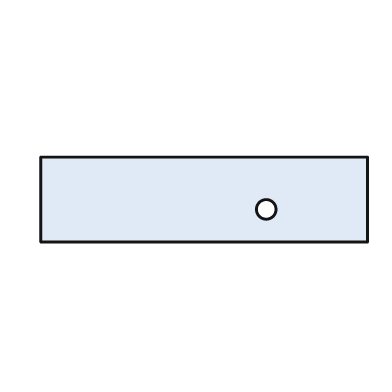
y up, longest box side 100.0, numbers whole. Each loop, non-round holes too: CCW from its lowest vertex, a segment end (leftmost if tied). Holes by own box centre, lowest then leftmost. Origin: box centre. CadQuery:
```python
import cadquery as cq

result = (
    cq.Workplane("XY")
    .moveTo(-50.0, -13.0)
    .lineTo(50.0, -13.0)
    .lineTo(50.0, 13.0)
    .lineTo(-50.0, 13.0)
    .close()
    .moveTo(19.0, -3.0)
    .circle(3.0)
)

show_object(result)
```